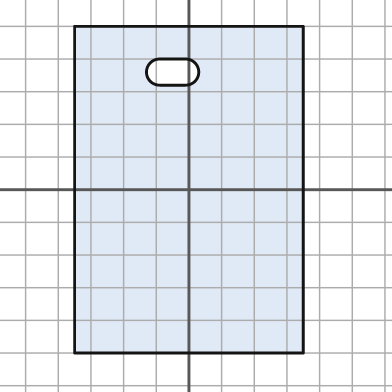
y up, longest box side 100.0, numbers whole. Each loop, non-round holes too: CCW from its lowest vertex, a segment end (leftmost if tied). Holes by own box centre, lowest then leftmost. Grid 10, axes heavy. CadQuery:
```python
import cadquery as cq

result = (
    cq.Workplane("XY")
    .moveTo(-35.0, -50.0)
    .lineTo(35.0, -50.0)
    .lineTo(35.0, 50.0)
    .lineTo(-35.0, 50.0)
    .close()
    .moveTo(-9.0, 32.0)
    .lineTo(-1.0, 32.0)
    .threePointArc((3.0, 36.0), (-1.0, 40.0))
    .lineTo(-9.0, 40.0)
    .threePointArc((-13.0, 36.0), (-9.0, 32.0))
    .close()
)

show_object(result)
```